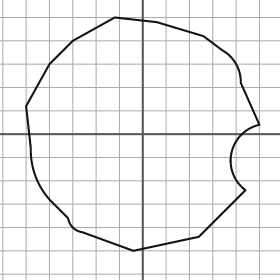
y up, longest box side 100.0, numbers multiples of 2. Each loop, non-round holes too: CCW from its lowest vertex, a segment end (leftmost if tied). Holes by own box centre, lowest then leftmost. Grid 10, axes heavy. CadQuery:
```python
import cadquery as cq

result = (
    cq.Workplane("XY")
    .moveTo(-4.0, -50.0)
    .lineTo(24.0, -44.0)
    .lineTo(44.0, -24.0)
    .threePointArc((38.0, -8.0), (50.0, 4.0))
    .lineTo(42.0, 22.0)
    .threePointArc((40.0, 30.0), (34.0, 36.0))
    .lineTo(26.0, 42.0)
    .lineTo(6.0, 48.0)
    .lineTo(-12.0, 50.0)
    .lineTo(-30.0, 40.0)
    .lineTo(-40.0, 30.0)
    .lineTo(-50.0, 12.0)
    .lineTo(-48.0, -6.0)
    .threePointArc((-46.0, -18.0), (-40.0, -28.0))
    .lineTo(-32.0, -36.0)
    .threePointArc((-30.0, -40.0), (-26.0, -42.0))
    .close()
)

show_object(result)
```